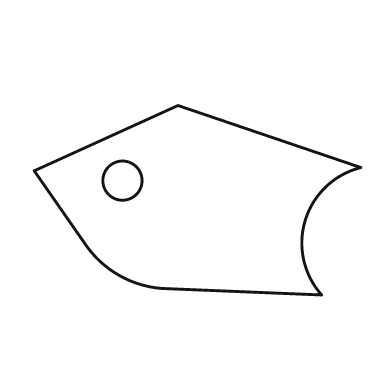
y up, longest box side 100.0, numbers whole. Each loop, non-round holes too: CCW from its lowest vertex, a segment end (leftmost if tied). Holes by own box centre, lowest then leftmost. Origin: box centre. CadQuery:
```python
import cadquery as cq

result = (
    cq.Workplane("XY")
    .moveTo(38.0, -29.0)
    .threePointArc((33.0, -6.0), (50.0, 10.0))
    .lineTo(-6.0, 29.0)
    .lineTo(-50.0, 9.0)
    .lineTo(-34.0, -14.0)
    .threePointArc((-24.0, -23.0), (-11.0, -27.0))
    .close()
    .moveTo(-23.0, 6.0)
    .circle(6.0)
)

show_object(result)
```